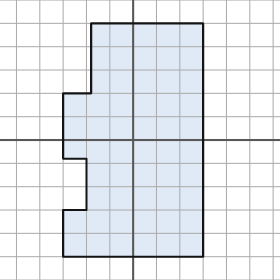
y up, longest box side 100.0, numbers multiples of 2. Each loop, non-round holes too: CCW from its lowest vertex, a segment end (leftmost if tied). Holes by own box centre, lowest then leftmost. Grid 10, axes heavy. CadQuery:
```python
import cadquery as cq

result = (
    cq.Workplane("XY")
    .moveTo(-30.0, -50.0)
    .lineTo(30.0, -50.0)
    .lineTo(30.0, 50.0)
    .lineTo(-18.0, 50.0)
    .lineTo(-18.0, 20.0)
    .lineTo(-30.0, 20.0)
    .lineTo(-30.0, -8.0)
    .lineTo(-20.0, -8.0)
    .lineTo(-20.0, -30.0)
    .lineTo(-30.0, -30.0)
    .close()
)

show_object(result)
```